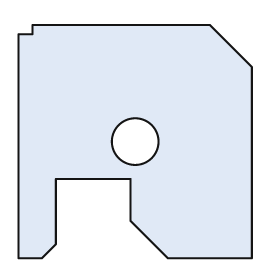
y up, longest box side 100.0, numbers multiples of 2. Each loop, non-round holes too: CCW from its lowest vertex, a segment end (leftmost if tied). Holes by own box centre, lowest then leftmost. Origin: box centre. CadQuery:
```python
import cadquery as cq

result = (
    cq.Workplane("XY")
    .moveTo(-50.0, -50.0)
    .lineTo(-40.0, -50.0)
    .lineTo(-34.0, -44.0)
    .lineTo(-34.0, -16.0)
    .lineTo(-2.0, -16.0)
    .lineTo(-2.0, -34.0)
    .lineTo(14.0, -50.0)
    .lineTo(50.0, -50.0)
    .lineTo(50.0, 32.0)
    .lineTo(32.0, 50.0)
    .lineTo(-44.0, 50.0)
    .lineTo(-44.0, 46.0)
    .lineTo(-50.0, 46.0)
    .close()
    .moveTo(0.0, 0.0)
    .circle(10.0)
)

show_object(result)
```